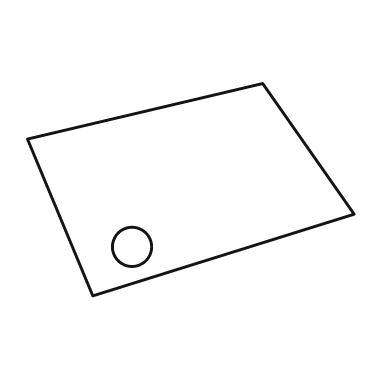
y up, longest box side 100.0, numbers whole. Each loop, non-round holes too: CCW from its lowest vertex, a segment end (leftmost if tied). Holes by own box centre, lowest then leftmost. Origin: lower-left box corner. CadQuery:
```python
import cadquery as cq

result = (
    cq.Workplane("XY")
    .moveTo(20.0, 0.0)
    .lineTo(100.0, 25.0)
    .lineTo(72.0, 65.0)
    .lineTo(0.0, 48.0)
    .close()
    .moveTo(32.0, 15.0)
    .circle(6.0)
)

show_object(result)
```